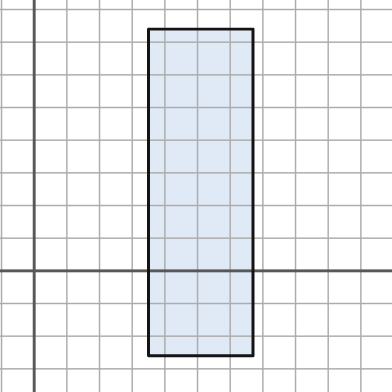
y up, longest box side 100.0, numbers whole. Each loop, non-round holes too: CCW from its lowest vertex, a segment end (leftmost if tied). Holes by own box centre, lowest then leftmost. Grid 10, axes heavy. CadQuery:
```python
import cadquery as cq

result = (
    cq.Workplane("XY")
    .moveTo(35.0, -26.0)
    .lineTo(67.0, -26.0)
    .lineTo(67.0, 74.0)
    .lineTo(35.0, 74.0)
    .close()
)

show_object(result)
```